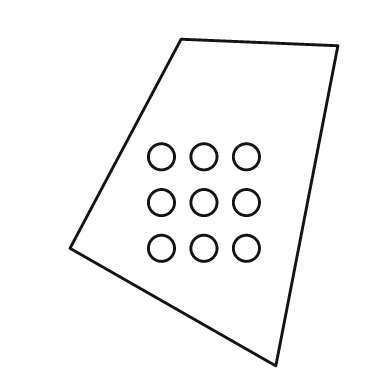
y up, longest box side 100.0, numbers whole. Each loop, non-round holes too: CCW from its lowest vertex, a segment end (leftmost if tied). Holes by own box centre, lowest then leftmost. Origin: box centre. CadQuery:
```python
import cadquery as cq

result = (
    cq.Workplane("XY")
    .moveTo(22.0, -50.0)
    .lineTo(41.0, 48.0)
    .lineTo(-7.0, 50.0)
    .lineTo(-41.0, -14.0)
    .close()
    .moveTo(-13.0, -14.0)
    .circle(4.0)
    .moveTo(0.0, -14.0)
    .circle(4.0)
    .moveTo(13.0, -14.0)
    .circle(4.0)
    .moveTo(-13.0, 0.0)
    .circle(4.0)
    .moveTo(0.0, 0.0)
    .circle(4.0)
    .moveTo(13.0, 0.0)
    .circle(4.0)
    .moveTo(-13.0, 14.0)
    .circle(4.0)
    .moveTo(0.0, 14.0)
    .circle(4.0)
    .moveTo(13.0, 14.0)
    .circle(4.0)
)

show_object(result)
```